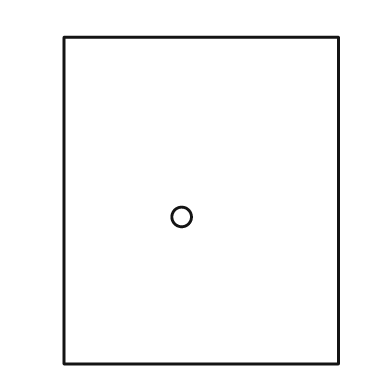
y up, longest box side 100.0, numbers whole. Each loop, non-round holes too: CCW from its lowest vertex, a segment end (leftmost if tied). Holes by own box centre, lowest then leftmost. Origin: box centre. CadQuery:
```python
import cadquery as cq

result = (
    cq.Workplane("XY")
    .moveTo(-42.0, -50.0)
    .lineTo(42.0, -50.0)
    .lineTo(42.0, 50.0)
    .lineTo(-42.0, 50.0)
    .close()
    .moveTo(-6.0, -5.0)
    .circle(3.0)
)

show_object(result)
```